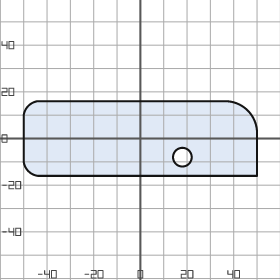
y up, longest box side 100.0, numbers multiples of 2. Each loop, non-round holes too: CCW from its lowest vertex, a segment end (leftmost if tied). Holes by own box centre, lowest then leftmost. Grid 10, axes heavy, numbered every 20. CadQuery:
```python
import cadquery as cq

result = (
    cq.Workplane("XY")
    .moveTo(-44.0, -16.0)
    .lineTo(50.0, -16.0)
    .lineTo(50.0, 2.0)
    .threePointArc((46.0, 12.0), (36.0, 16.0))
    .lineTo(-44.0, 16.0)
    .threePointArc((-48.0, 14.0), (-50.0, 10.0))
    .lineTo(-50.0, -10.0)
    .threePointArc((-48.0, -14.0), (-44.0, -16.0))
    .close()
    .moveTo(18.0, -8.0)
    .circle(4.0)
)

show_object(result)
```